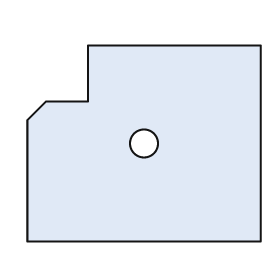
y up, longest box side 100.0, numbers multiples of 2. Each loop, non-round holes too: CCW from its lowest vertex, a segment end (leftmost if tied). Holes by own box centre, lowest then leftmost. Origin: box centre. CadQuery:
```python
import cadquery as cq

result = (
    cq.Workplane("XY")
    .moveTo(-50.0, -42.0)
    .lineTo(50.0, -42.0)
    .lineTo(50.0, 42.0)
    .lineTo(-24.0, 42.0)
    .lineTo(-24.0, 18.0)
    .lineTo(-42.0, 18.0)
    .lineTo(-50.0, 10.0)
    .close()
    .moveTo(0.0, 0.0)
    .circle(6.0)
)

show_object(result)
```